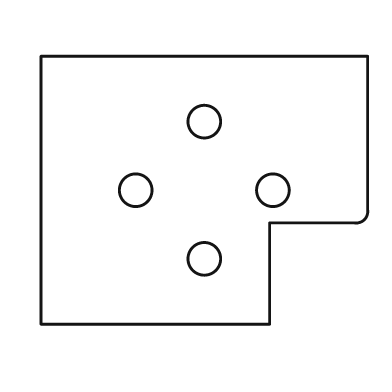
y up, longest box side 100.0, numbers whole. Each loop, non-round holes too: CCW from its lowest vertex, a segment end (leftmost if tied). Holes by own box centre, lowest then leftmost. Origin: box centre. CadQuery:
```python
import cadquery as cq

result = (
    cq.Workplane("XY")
    .moveTo(-50.0, -41.0)
    .lineTo(20.0, -41.0)
    .lineTo(20.0, -10.0)
    .lineTo(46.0, -10.0)
    .threePointArc((49.0, -9.0), (50.0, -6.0))
    .lineTo(50.0, 41.0)
    .lineTo(-50.0, 41.0)
    .close()
    .moveTo(0.0, -21.0)
    .circle(5.0)
    .moveTo(-21.0, 0.0)
    .circle(5.0)
    .moveTo(21.0, 0.0)
    .circle(5.0)
    .moveTo(0.0, 21.0)
    .circle(5.0)
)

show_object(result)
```